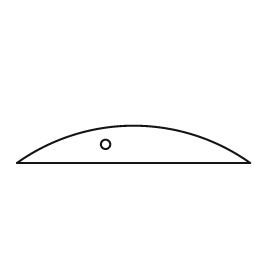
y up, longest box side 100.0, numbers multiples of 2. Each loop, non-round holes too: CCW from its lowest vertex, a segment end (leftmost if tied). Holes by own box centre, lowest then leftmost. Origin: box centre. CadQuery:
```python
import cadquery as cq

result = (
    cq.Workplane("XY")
    .moveTo(-50.0, -8.0)
    .lineTo(50.0, -8.0)
    .threePointArc((0.0, 8.0), (-50.0, -8.0))
    .close()
    .moveTo(-12.0, 0.0)
    .circle(2.0)
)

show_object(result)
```